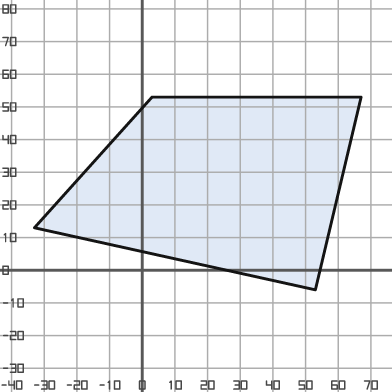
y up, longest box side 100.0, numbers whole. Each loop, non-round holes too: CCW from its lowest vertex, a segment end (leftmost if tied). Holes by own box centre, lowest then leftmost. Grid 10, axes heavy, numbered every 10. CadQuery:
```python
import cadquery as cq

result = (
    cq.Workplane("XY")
    .moveTo(53.0, -6.0)
    .lineTo(67.0, 53.0)
    .lineTo(3.0, 53.0)
    .lineTo(-33.0, 13.0)
    .close()
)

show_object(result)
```